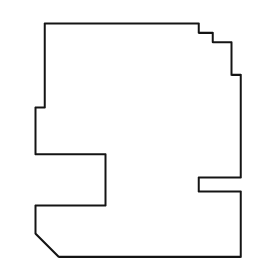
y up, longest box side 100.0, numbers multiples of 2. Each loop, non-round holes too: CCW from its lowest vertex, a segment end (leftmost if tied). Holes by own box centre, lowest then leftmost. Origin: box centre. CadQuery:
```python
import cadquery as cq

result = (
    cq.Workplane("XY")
    .moveTo(-34.0, -50.0)
    .lineTo(44.0, -50.0)
    .lineTo(44.0, -22.0)
    .lineTo(26.0, -22.0)
    .lineTo(26.0, -16.0)
    .lineTo(44.0, -16.0)
    .lineTo(44.0, 28.0)
    .lineTo(40.0, 28.0)
    .lineTo(40.0, 42.0)
    .lineTo(32.0, 42.0)
    .lineTo(32.0, 46.0)
    .lineTo(26.0, 46.0)
    .lineTo(26.0, 50.0)
    .lineTo(-40.0, 50.0)
    .lineTo(-40.0, 14.0)
    .lineTo(-44.0, 14.0)
    .lineTo(-44.0, -6.0)
    .lineTo(-14.0, -6.0)
    .lineTo(-14.0, -28.0)
    .lineTo(-44.0, -28.0)
    .lineTo(-44.0, -40.0)
    .close()
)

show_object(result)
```